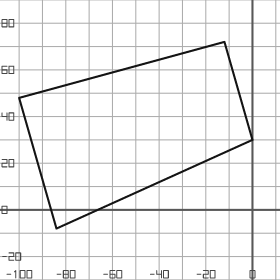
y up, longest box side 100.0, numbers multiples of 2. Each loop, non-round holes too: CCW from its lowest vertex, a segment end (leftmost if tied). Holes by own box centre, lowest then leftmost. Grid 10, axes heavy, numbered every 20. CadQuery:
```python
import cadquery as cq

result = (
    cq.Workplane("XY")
    .moveTo(-84.0, -8.0)
    .lineTo(0.0, 30.0)
    .lineTo(-12.0, 72.0)
    .lineTo(-100.0, 48.0)
    .close()
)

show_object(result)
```